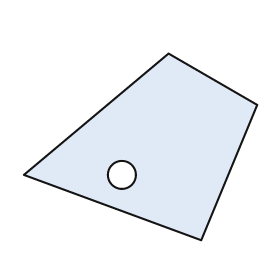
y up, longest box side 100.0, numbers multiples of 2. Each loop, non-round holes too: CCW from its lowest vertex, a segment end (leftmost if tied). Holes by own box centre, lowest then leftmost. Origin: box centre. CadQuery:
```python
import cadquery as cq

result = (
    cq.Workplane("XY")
    .moveTo(26.0, -40.0)
    .lineTo(50.0, 18.0)
    .lineTo(12.0, 40.0)
    .lineTo(-50.0, -12.0)
    .close()
    .moveTo(-8.0, -12.0)
    .circle(6.0)
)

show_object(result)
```